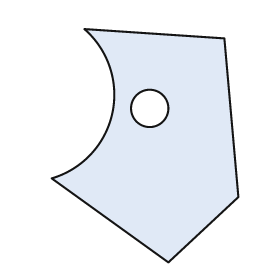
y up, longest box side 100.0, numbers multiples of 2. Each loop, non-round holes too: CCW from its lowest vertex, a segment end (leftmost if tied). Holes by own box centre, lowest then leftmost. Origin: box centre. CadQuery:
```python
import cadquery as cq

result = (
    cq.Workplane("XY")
    .moveTo(10.0, -50.0)
    .lineTo(40.0, -22.0)
    .lineTo(34.0, 46.0)
    .lineTo(-26.0, 50.0)
    .threePointArc((-14.0, 14.0), (-40.0, -14.0))
    .close()
    .moveTo(2.0, 16.0)
    .circle(8.0)
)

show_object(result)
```